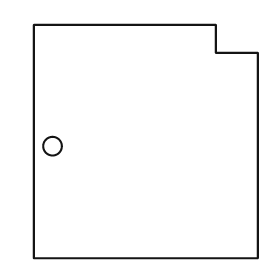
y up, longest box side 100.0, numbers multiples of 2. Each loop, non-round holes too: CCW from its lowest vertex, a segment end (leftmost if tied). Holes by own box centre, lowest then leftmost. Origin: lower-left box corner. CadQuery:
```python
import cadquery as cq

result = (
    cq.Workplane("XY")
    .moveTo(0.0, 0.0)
    .lineTo(96.0, 0.0)
    .lineTo(96.0, 88.0)
    .lineTo(78.0, 88.0)
    .lineTo(78.0, 100.0)
    .lineTo(0.0, 100.0)
    .close()
    .moveTo(8.0, 48.0)
    .circle(4.0)
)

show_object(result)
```